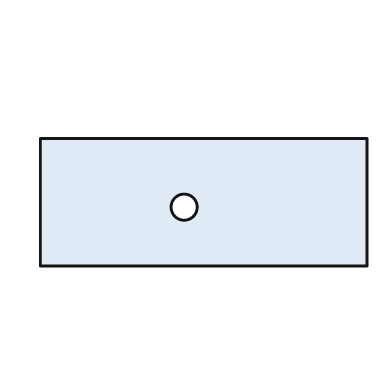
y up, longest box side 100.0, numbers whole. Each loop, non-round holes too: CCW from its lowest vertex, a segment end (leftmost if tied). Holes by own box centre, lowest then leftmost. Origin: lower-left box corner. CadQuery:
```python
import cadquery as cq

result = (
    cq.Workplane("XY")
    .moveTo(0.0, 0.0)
    .lineTo(100.0, 0.0)
    .lineTo(100.0, 39.0)
    .lineTo(0.0, 39.0)
    .close()
    .moveTo(44.0, 18.0)
    .circle(4.0)
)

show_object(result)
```